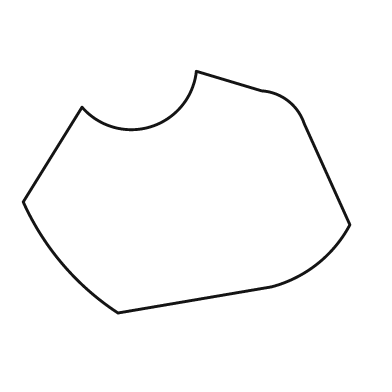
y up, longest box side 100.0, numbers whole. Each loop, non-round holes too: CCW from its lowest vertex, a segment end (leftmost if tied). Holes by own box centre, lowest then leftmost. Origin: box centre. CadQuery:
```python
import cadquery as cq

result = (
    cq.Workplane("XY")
    .moveTo(-21.0, -37.0)
    .lineTo(26.0, -29.0)
    .threePointArc((40.0, -22.0), (50.0, -10.0))
    .lineTo(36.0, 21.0)
    .threePointArc((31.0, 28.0), (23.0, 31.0))
    .lineTo(3.0, 37.0)
    .threePointArc((-11.0, 20.0), (-32.0, 26.0))
    .lineTo(-50.0, -3.0)
    .threePointArc((-38.0, -22.0), (-21.0, -37.0))
    .close()
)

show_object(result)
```